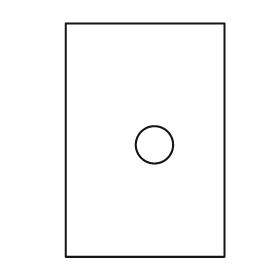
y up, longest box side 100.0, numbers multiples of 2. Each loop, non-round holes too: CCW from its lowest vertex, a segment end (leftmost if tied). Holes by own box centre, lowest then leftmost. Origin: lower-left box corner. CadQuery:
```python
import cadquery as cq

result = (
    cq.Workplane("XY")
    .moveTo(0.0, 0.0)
    .lineTo(68.0, 0.0)
    .lineTo(68.0, 100.0)
    .lineTo(0.0, 100.0)
    .close()
    .moveTo(38.0, 48.0)
    .circle(8.0)
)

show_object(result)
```